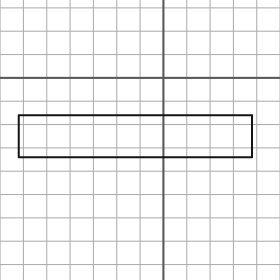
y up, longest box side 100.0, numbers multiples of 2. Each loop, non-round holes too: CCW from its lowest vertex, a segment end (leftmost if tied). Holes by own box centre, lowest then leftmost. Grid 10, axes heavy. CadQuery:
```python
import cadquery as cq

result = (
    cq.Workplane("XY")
    .moveTo(-62.0, -34.0)
    .lineTo(38.0, -34.0)
    .lineTo(38.0, -16.0)
    .lineTo(-62.0, -16.0)
    .close()
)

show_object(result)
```